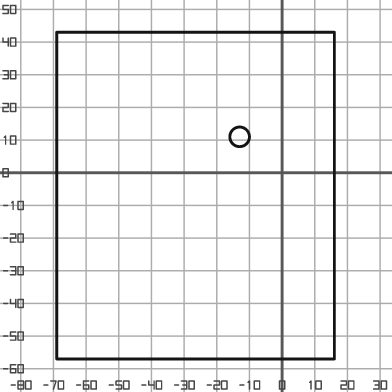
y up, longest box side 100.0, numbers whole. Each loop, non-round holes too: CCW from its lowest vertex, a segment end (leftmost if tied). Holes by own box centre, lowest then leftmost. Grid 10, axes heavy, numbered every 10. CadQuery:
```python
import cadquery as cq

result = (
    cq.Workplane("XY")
    .moveTo(-69.0, -57.0)
    .lineTo(16.0, -57.0)
    .lineTo(16.0, 43.0)
    .lineTo(-69.0, 43.0)
    .close()
    .moveTo(-13.0, 11.0)
    .circle(3.0)
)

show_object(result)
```